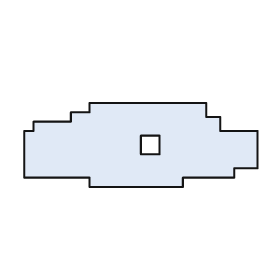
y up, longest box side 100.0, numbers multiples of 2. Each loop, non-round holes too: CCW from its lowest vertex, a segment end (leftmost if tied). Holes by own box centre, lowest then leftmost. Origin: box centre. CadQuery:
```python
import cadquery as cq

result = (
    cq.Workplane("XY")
    .moveTo(-22.0, -18.0)
    .lineTo(18.0, -18.0)
    .lineTo(18.0, -14.0)
    .lineTo(40.0, -14.0)
    .lineTo(40.0, -10.0)
    .lineTo(50.0, -10.0)
    .lineTo(50.0, 6.0)
    .lineTo(34.0, 6.0)
    .lineTo(34.0, 12.0)
    .lineTo(28.0, 12.0)
    .lineTo(28.0, 18.0)
    .lineTo(-22.0, 18.0)
    .lineTo(-22.0, 14.0)
    .lineTo(-30.0, 14.0)
    .lineTo(-30.0, 10.0)
    .lineTo(-46.0, 10.0)
    .lineTo(-46.0, 6.0)
    .lineTo(-50.0, 6.0)
    .lineTo(-50.0, -14.0)
    .lineTo(-22.0, -14.0)
    .close()
    .moveTo(0.0, -4.0)
    .lineTo(8.0, -4.0)
    .lineTo(8.0, 4.0)
    .lineTo(0.0, 4.0)
    .close()
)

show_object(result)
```